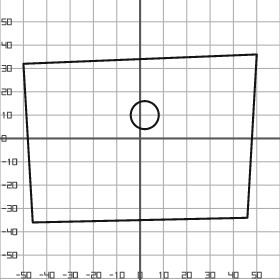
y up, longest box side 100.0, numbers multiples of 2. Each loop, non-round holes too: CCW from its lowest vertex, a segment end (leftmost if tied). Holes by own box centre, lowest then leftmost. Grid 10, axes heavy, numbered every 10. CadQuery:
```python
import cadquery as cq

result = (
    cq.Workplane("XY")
    .moveTo(-46.0, -36.0)
    .lineTo(46.0, -34.0)
    .lineTo(50.0, 36.0)
    .lineTo(-50.0, 32.0)
    .close()
    .moveTo(2.0, 10.0)
    .circle(6.0)
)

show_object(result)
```